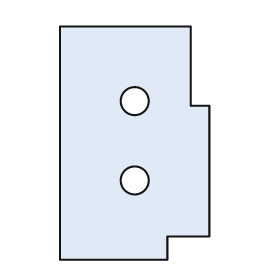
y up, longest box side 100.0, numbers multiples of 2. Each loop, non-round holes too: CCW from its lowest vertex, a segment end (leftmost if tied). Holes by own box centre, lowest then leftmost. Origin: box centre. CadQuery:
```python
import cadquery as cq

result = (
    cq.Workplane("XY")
    .moveTo(-32.0, -50.0)
    .lineTo(14.0, -50.0)
    .lineTo(14.0, -40.0)
    .lineTo(32.0, -40.0)
    .lineTo(32.0, 16.0)
    .lineTo(24.0, 16.0)
    .lineTo(24.0, 50.0)
    .lineTo(-32.0, 50.0)
    .close()
    .moveTo(0.0, -16.0)
    .circle(6.0)
    .moveTo(0.0, 18.0)
    .circle(6.0)
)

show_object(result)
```